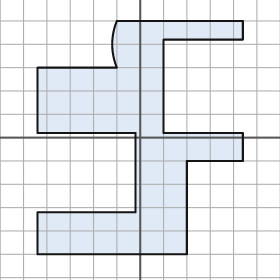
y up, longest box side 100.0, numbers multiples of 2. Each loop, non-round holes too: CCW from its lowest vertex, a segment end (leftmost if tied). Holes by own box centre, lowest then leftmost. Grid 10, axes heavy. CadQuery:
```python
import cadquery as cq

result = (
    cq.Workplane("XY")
    .moveTo(-44.0, -50.0)
    .lineTo(20.0, -50.0)
    .lineTo(20.0, -10.0)
    .lineTo(44.0, -10.0)
    .lineTo(44.0, 2.0)
    .lineTo(10.0, 2.0)
    .lineTo(10.0, 42.0)
    .lineTo(44.0, 42.0)
    .lineTo(44.0, 50.0)
    .lineTo(-10.0, 50.0)
    .threePointArc((-12.0, 40.0), (-10.0, 30.0))
    .lineTo(-44.0, 30.0)
    .lineTo(-44.0, 2.0)
    .lineTo(-2.0, 2.0)
    .lineTo(-2.0, -32.0)
    .lineTo(-44.0, -32.0)
    .close()
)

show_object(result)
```